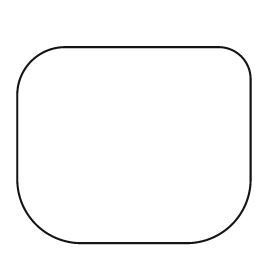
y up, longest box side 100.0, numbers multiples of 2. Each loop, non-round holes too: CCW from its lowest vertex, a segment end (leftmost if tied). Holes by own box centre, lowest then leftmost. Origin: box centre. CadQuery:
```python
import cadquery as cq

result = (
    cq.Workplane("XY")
    .moveTo(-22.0, -42.0)
    .lineTo(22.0, -42.0)
    .threePointArc((42.0, -34.0), (50.0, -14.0))
    .lineTo(50.0, 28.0)
    .threePointArc((46.0, 38.0), (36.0, 42.0))
    .lineTo(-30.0, 42.0)
    .threePointArc((-44.0, 36.0), (-50.0, 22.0))
    .lineTo(-50.0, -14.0)
    .threePointArc((-42.0, -34.0), (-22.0, -42.0))
    .close()
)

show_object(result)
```